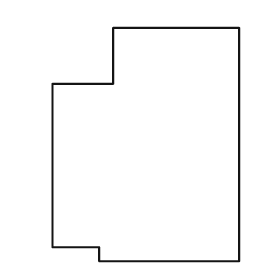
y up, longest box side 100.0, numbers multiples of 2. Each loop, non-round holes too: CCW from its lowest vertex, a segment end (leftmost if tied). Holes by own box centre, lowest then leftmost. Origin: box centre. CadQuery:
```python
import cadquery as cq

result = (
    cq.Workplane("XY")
    .moveTo(-20.0, -50.0)
    .lineTo(40.0, -50.0)
    .lineTo(40.0, 50.0)
    .lineTo(-14.0, 50.0)
    .lineTo(-14.0, 26.0)
    .lineTo(-40.0, 26.0)
    .lineTo(-40.0, -44.0)
    .lineTo(-20.0, -44.0)
    .close()
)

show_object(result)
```